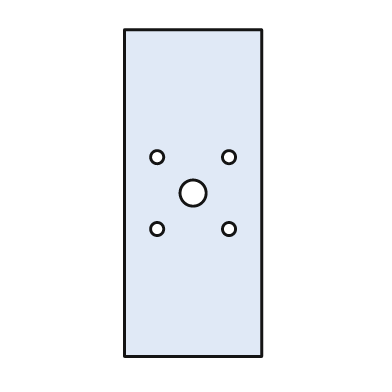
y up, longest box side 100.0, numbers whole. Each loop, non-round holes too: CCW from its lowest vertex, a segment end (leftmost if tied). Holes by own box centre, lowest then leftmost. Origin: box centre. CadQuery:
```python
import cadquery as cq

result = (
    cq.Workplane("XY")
    .moveTo(-21.0, -50.0)
    .lineTo(21.0, -50.0)
    .lineTo(21.0, 50.0)
    .lineTo(-21.0, 50.0)
    .close()
    .moveTo(-11.0, -11.0)
    .circle(2.0)
    .moveTo(11.0, -11.0)
    .circle(2.0)
    .moveTo(0.0, 0.0)
    .circle(4.0)
    .moveTo(-11.0, 11.0)
    .circle(2.0)
    .moveTo(11.0, 11.0)
    .circle(2.0)
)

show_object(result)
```